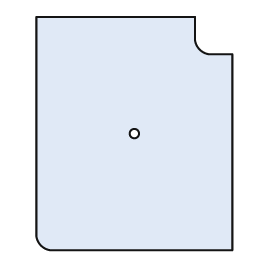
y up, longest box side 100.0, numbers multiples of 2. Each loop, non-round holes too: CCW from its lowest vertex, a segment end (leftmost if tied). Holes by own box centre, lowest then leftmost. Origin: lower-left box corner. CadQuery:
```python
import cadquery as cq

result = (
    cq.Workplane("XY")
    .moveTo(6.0, 0.0)
    .lineTo(84.0, 0.0)
    .lineTo(84.0, 84.0)
    .lineTo(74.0, 84.0)
    .threePointArc((70.0, 86.0), (68.0, 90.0))
    .lineTo(68.0, 100.0)
    .lineTo(0.0, 100.0)
    .lineTo(0.0, 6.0)
    .threePointArc((2.0, 2.0), (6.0, 0.0))
    .close()
    .moveTo(42.0, 50.0)
    .circle(2.0)
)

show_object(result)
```